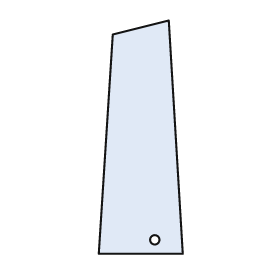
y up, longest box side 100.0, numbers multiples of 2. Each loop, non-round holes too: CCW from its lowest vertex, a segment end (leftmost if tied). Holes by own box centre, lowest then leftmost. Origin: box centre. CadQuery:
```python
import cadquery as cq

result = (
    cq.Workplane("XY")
    .moveTo(-18.0, -50.0)
    .lineTo(18.0, -50.0)
    .lineTo(12.0, 50.0)
    .lineTo(-12.0, 44.0)
    .close()
    .moveTo(6.0, -44.0)
    .circle(2.0)
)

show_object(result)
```